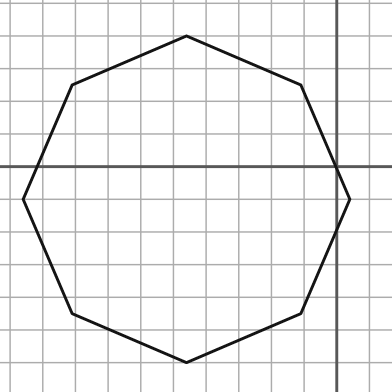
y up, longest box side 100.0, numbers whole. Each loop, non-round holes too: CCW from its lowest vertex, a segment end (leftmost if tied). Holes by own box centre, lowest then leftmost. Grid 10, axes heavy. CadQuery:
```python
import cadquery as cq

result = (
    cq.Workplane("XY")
    .moveTo(-46.0, -60.0)
    .lineTo(-11.0, -45.0)
    .lineTo(4.0, -10.0)
    .lineTo(-11.0, 25.0)
    .lineTo(-46.0, 40.0)
    .lineTo(-81.0, 25.0)
    .lineTo(-96.0, -10.0)
    .lineTo(-81.0, -45.0)
    .close()
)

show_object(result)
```